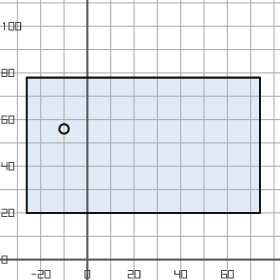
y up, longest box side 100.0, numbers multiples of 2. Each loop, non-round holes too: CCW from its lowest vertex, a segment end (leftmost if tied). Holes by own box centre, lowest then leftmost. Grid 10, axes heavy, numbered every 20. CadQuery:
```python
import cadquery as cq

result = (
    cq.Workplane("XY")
    .moveTo(-26.0, 20.0)
    .lineTo(74.0, 20.0)
    .lineTo(74.0, 78.0)
    .lineTo(-26.0, 78.0)
    .close()
    .moveTo(-10.0, 56.0)
    .circle(2.0)
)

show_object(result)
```